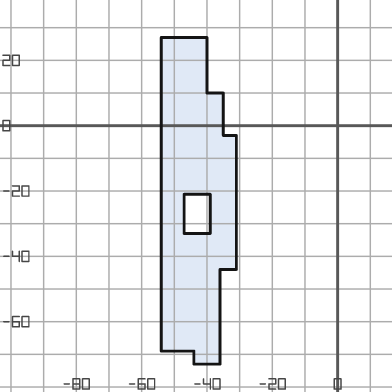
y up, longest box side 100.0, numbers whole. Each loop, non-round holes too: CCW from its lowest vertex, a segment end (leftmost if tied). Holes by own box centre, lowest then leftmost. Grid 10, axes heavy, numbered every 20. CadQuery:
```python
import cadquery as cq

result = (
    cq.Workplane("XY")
    .moveTo(-44.0, -73.0)
    .lineTo(-36.0, -73.0)
    .lineTo(-36.0, -44.0)
    .lineTo(-31.0, -44.0)
    .lineTo(-31.0, -3.0)
    .lineTo(-35.0, -3.0)
    .lineTo(-35.0, 10.0)
    .lineTo(-40.0, 10.0)
    .lineTo(-40.0, 27.0)
    .lineTo(-54.0, 27.0)
    .lineTo(-54.0, -69.0)
    .lineTo(-44.0, -69.0)
    .close()
    .moveTo(-47.0, -33.0)
    .lineTo(-39.0, -33.0)
    .lineTo(-39.0, -21.0)
    .lineTo(-47.0, -21.0)
    .close()
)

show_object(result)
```